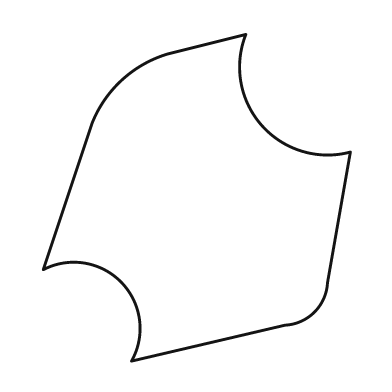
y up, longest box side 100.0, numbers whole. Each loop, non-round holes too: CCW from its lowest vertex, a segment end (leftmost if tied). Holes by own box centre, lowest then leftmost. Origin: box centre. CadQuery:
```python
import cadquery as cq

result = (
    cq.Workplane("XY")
    .moveTo(-20.0, -50.0)
    .lineTo(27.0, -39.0)
    .threePointArc((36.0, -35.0), (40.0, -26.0))
    .lineTo(47.0, 14.0)
    .threePointArc((20.0, 22.0), (15.0, 50.0))
    .lineTo(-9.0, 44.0)
    .threePointArc((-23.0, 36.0), (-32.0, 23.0))
    .lineTo(-47.0, -22.0)
    .threePointArc((-23.0, -26.0), (-20.0, -50.0))
    .close()
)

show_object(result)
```